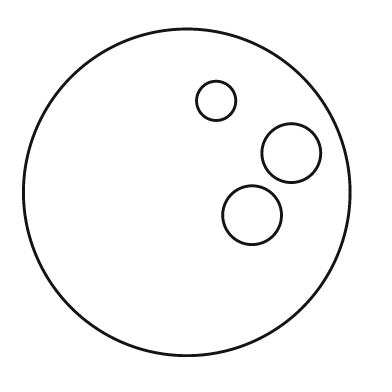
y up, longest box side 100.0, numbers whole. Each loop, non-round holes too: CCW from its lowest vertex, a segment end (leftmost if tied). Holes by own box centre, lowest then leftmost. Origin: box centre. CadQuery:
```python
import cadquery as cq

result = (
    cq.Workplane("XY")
    .moveTo(0.0, 0.0)
    .circle(50.0)
    .moveTo(20.0, -7.0)
    .circle(9.0)
    .moveTo(32.0, 12.0)
    .circle(9.0)
    .moveTo(9.0, 28.0)
    .circle(6.0)
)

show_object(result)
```